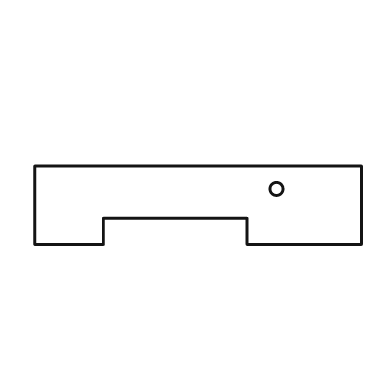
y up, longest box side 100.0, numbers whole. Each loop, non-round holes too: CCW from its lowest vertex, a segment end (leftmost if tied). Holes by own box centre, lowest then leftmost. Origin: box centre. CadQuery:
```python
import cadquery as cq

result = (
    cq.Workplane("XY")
    .moveTo(-50.0, -12.0)
    .lineTo(-29.0, -12.0)
    .lineTo(-29.0, -4.0)
    .lineTo(15.0, -4.0)
    .lineTo(15.0, -12.0)
    .lineTo(50.0, -12.0)
    .lineTo(50.0, 12.0)
    .lineTo(-50.0, 12.0)
    .close()
    .moveTo(24.0, 5.0)
    .circle(2.0)
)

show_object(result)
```